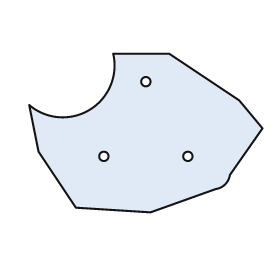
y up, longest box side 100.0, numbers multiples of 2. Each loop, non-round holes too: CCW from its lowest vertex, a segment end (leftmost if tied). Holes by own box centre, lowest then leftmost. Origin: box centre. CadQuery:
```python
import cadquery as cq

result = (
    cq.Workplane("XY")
    .moveTo(2.0, -34.0)
    .lineTo(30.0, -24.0)
    .threePointArc((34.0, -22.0), (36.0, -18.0))
    .lineTo(50.0, 2.0)
    .lineTo(40.0, 14.0)
    .lineTo(10.0, 34.0)
    .lineTo(-14.0, 34.0)
    .threePointArc((-24.0, 10.0), (-50.0, 12.0))
    .lineTo(-46.0, -8.0)
    .lineTo(-30.0, -32.0)
    .close()
    .moveTo(-18.0, -10.0)
    .circle(2.0)
    .moveTo(18.0, -10.0)
    .circle(2.0)
    .moveTo(0.0, 22.0)
    .circle(2.0)
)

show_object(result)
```